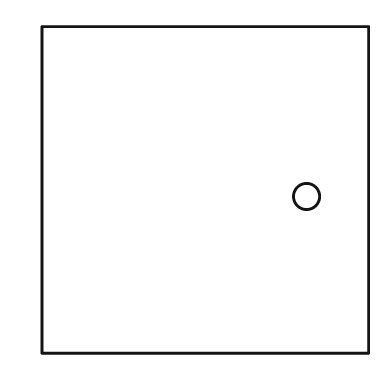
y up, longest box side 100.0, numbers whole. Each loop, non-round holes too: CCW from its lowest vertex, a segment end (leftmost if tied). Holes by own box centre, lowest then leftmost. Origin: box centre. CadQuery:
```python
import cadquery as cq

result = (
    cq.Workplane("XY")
    .moveTo(-50.0, -50.0)
    .lineTo(50.0, -50.0)
    .lineTo(50.0, 50.0)
    .lineTo(-50.0, 50.0)
    .close()
    .moveTo(31.0, -2.0)
    .circle(4.0)
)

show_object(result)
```